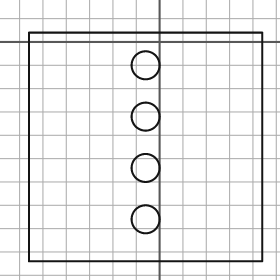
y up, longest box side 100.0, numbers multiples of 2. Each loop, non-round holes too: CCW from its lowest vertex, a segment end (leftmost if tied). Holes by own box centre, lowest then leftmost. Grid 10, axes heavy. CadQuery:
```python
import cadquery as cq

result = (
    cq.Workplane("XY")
    .moveTo(-56.0, -94.0)
    .lineTo(44.0, -94.0)
    .lineTo(44.0, 4.0)
    .lineTo(-56.0, 4.0)
    .close()
    .moveTo(-6.0, -76.0)
    .circle(6.0)
    .moveTo(-6.0, -54.0)
    .circle(6.0)
    .moveTo(-6.0, -32.0)
    .circle(6.0)
    .moveTo(-6.0, -10.0)
    .circle(6.0)
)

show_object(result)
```